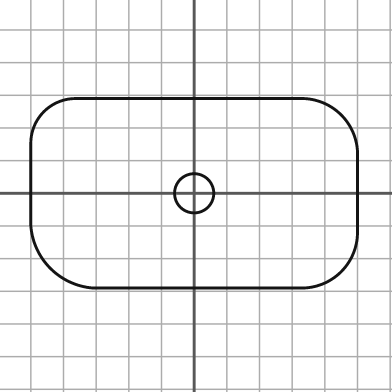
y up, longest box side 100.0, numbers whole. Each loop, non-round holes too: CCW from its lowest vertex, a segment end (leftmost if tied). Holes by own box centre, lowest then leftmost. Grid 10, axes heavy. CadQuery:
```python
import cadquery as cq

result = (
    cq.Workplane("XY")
    .moveTo(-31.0, -29.0)
    .lineTo(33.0, -29.0)
    .threePointArc((45.0, -24.0), (50.0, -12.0))
    .lineTo(50.0, 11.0)
    .threePointArc((45.0, 24.0), (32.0, 29.0))
    .lineTo(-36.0, 29.0)
    .threePointArc((-46.0, 25.0), (-50.0, 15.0))
    .lineTo(-50.0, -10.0)
    .threePointArc((-44.0, -23.0), (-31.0, -29.0))
    .close()
    .moveTo(0.0, 0.0)
    .circle(6.0)
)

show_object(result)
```